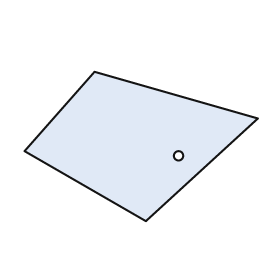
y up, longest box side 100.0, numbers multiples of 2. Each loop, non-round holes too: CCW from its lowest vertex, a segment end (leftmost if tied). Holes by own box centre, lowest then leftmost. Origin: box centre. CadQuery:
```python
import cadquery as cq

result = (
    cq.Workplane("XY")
    .moveTo(2.0, -32.0)
    .lineTo(50.0, 12.0)
    .lineTo(-20.0, 32.0)
    .lineTo(-50.0, -2.0)
    .close()
    .moveTo(16.0, -4.0)
    .circle(2.0)
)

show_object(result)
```